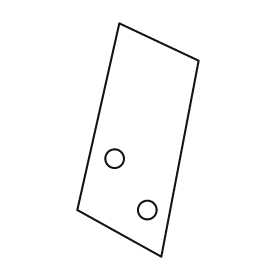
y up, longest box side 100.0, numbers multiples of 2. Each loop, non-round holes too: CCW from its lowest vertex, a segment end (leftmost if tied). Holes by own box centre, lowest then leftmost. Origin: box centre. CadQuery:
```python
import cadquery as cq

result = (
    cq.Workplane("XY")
    .moveTo(10.0, -50.0)
    .lineTo(26.0, 34.0)
    .lineTo(-8.0, 50.0)
    .lineTo(-26.0, -30.0)
    .close()
    .moveTo(4.0, -30.0)
    .circle(4.0)
    .moveTo(-10.0, -8.0)
    .circle(4.0)
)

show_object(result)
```